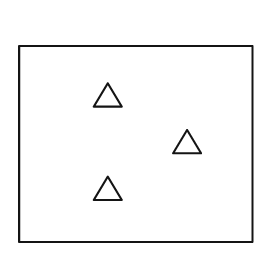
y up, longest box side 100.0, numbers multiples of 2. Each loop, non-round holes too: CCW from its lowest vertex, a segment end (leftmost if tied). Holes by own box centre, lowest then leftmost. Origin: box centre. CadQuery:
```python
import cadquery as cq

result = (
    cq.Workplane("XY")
    .moveTo(-50.0, -42.0)
    .lineTo(50.0, -42.0)
    .lineTo(50.0, 42.0)
    .lineTo(-50.0, 42.0)
    .close()
    .moveTo(-18.0, -24.0)
    .lineTo(-6.0, -24.0)
    .lineTo(-12.0, -14.0)
    .close()
    .moveTo(16.0, -4.0)
    .lineTo(28.0, -4.0)
    .lineTo(22.0, 6.0)
    .close()
    .moveTo(-18.0, 16.0)
    .lineTo(-6.0, 16.0)
    .lineTo(-12.0, 26.0)
    .close()
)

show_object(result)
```